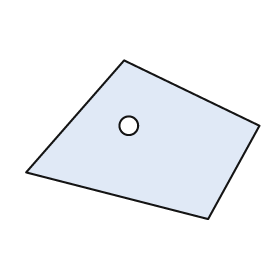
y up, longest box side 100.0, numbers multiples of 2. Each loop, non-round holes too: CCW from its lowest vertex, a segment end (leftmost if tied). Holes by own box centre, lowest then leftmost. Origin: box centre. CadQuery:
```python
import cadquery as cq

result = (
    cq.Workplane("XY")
    .moveTo(28.0, -34.0)
    .lineTo(50.0, 6.0)
    .lineTo(-8.0, 34.0)
    .lineTo(-50.0, -14.0)
    .close()
    .moveTo(-6.0, 6.0)
    .circle(4.0)
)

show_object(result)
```